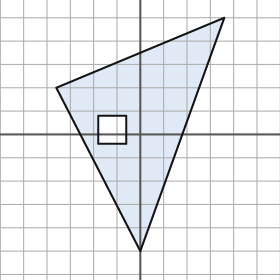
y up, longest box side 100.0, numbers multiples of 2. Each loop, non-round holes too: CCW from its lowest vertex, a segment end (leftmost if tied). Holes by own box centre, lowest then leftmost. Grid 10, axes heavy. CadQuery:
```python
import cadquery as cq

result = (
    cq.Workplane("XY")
    .moveTo(0.0, -50.0)
    .lineTo(36.0, 50.0)
    .lineTo(-36.0, 20.0)
    .close()
    .moveTo(-18.0, -4.0)
    .lineTo(-6.0, -4.0)
    .lineTo(-6.0, 8.0)
    .lineTo(-18.0, 8.0)
    .close()
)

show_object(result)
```